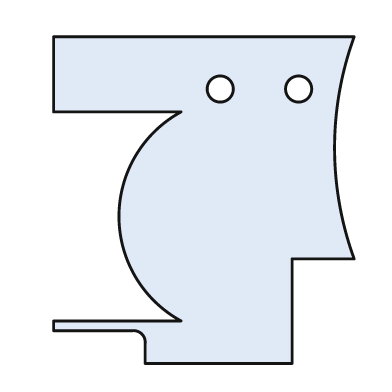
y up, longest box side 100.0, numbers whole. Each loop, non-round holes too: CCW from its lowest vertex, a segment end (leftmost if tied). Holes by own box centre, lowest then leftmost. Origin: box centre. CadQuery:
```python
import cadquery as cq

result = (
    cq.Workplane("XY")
    .moveTo(-18.0, -50.0)
    .lineTo(27.0, -50.0)
    .lineTo(27.0, -18.0)
    .lineTo(46.0, -18.0)
    .threePointArc((40.0, 16.0), (46.0, 50.0))
    .lineTo(-46.0, 50.0)
    .lineTo(-46.0, 27.0)
    .lineTo(-7.0, 27.0)
    .threePointArc((-26.0, -5.0), (-7.0, -37.0))
    .lineTo(-46.0, -37.0)
    .lineTo(-46.0, -40.0)
    .lineTo(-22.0, -40.0)
    .threePointArc((-19.0, -41.0), (-18.0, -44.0))
    .close()
    .moveTo(5.0, 34.0)
    .circle(4.0)
    .moveTo(29.0, 34.0)
    .circle(4.0)
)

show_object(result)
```